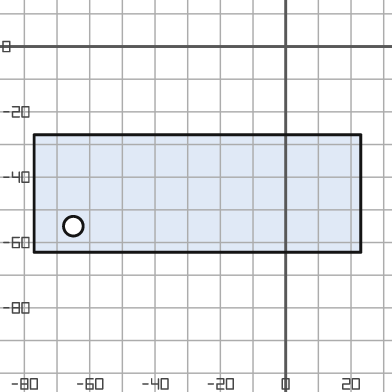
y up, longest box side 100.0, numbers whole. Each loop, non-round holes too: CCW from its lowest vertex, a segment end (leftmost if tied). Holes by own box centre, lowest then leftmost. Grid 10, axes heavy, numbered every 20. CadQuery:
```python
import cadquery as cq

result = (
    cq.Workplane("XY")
    .moveTo(-77.0, -63.0)
    .lineTo(23.0, -63.0)
    .lineTo(23.0, -27.0)
    .lineTo(-77.0, -27.0)
    .close()
    .moveTo(-65.0, -55.0)
    .circle(3.0)
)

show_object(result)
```